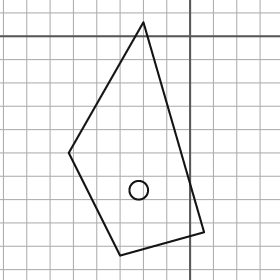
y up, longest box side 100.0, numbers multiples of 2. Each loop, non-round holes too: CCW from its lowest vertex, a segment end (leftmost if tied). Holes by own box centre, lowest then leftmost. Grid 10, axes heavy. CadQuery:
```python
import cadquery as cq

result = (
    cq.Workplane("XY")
    .moveTo(-30.0, -94.0)
    .lineTo(6.0, -84.0)
    .lineTo(-20.0, 6.0)
    .lineTo(-52.0, -50.0)
    .close()
    .moveTo(-22.0, -66.0)
    .circle(4.0)
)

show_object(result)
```